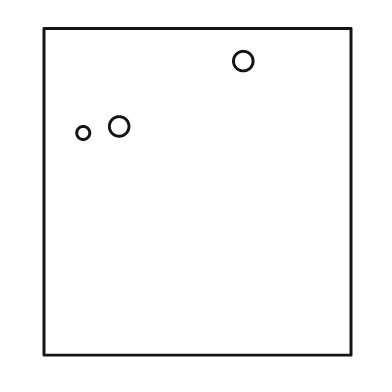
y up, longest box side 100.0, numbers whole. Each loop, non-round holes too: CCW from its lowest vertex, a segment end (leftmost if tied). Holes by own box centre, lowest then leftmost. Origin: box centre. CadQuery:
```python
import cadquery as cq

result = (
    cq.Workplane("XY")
    .moveTo(-47.0, -50.0)
    .lineTo(47.0, -50.0)
    .lineTo(47.0, 50.0)
    .lineTo(-47.0, 50.0)
    .close()
    .moveTo(-35.0, 18.0)
    .circle(2.0)
    .moveTo(-24.0, 20.0)
    .circle(3.0)
    .moveTo(14.0, 40.0)
    .circle(3.0)
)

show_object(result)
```